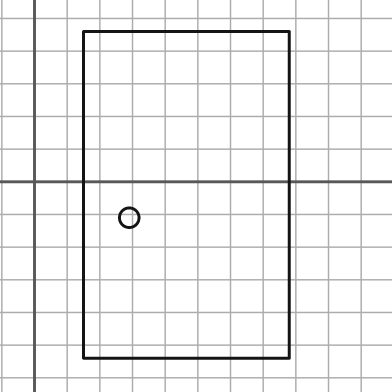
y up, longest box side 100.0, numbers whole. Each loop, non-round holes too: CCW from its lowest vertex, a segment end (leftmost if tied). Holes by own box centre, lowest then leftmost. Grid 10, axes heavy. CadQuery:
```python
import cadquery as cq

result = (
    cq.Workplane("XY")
    .moveTo(15.0, -54.0)
    .lineTo(78.0, -54.0)
    .lineTo(78.0, 46.0)
    .lineTo(15.0, 46.0)
    .close()
    .moveTo(29.0, -11.0)
    .circle(3.0)
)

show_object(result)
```